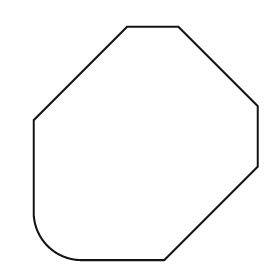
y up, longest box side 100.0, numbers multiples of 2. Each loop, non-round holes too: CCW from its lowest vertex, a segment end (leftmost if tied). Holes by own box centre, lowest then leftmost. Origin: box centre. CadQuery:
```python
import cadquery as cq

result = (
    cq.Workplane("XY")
    .moveTo(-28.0, -50.0)
    .lineTo(8.0, -50.0)
    .lineTo(48.0, -10.0)
    .lineTo(48.0, 16.0)
    .lineTo(14.0, 50.0)
    .lineTo(-8.0, 50.0)
    .lineTo(-48.0, 10.0)
    .lineTo(-48.0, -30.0)
    .threePointArc((-42.0, -44.0), (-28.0, -50.0))
    .close()
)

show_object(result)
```